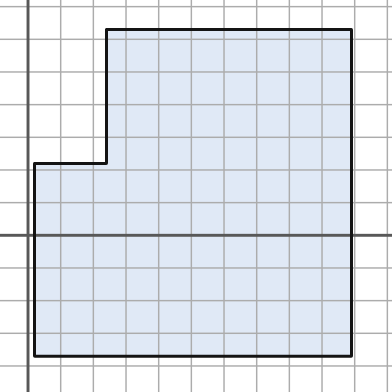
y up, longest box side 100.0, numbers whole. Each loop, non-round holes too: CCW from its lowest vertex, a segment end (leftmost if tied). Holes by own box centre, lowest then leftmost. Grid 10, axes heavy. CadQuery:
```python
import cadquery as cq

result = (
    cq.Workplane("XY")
    .moveTo(2.0, -37.0)
    .lineTo(99.0, -37.0)
    .lineTo(99.0, 63.0)
    .lineTo(24.0, 63.0)
    .lineTo(24.0, 22.0)
    .lineTo(2.0, 22.0)
    .close()
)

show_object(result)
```